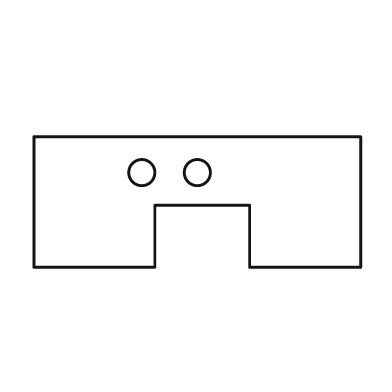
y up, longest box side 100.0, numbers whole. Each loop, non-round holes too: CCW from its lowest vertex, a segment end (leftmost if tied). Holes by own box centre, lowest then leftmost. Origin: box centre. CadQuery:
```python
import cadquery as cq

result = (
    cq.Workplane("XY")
    .moveTo(-50.0, -20.0)
    .lineTo(-13.0, -20.0)
    .lineTo(-13.0, -1.0)
    .lineTo(16.0, -1.0)
    .lineTo(16.0, -20.0)
    .lineTo(50.0, -20.0)
    .lineTo(50.0, 20.0)
    .lineTo(-50.0, 20.0)
    .close()
    .moveTo(-17.0, 9.0)
    .circle(4.0)
    .moveTo(0.0, 9.0)
    .circle(4.0)
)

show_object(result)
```